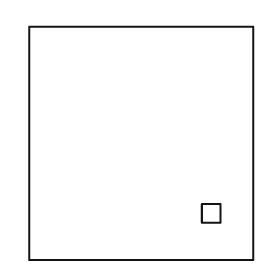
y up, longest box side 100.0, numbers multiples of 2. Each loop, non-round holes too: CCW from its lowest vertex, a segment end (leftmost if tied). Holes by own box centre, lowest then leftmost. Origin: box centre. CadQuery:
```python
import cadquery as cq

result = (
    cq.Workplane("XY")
    .moveTo(-48.0, -50.0)
    .lineTo(48.0, -50.0)
    .lineTo(48.0, 50.0)
    .lineTo(-48.0, 50.0)
    .close()
    .moveTo(26.0, -34.0)
    .lineTo(34.0, -34.0)
    .lineTo(34.0, -26.0)
    .lineTo(26.0, -26.0)
    .close()
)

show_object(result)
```